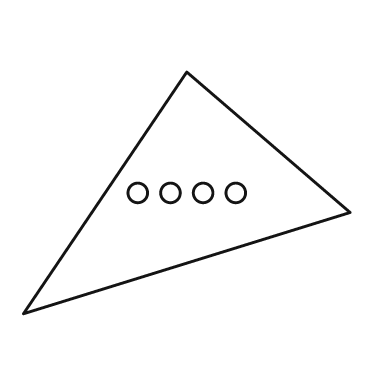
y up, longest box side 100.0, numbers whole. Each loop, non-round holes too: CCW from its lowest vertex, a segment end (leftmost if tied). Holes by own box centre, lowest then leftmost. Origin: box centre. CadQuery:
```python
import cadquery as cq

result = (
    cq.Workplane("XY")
    .moveTo(-50.0, -37.0)
    .lineTo(50.0, -6.0)
    .lineTo(0.0, 37.0)
    .close()
    .moveTo(-15.0, 0.0)
    .circle(3.0)
    .moveTo(-5.0, 0.0)
    .circle(3.0)
    .moveTo(5.0, 0.0)
    .circle(3.0)
    .moveTo(15.0, 0.0)
    .circle(3.0)
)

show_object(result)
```